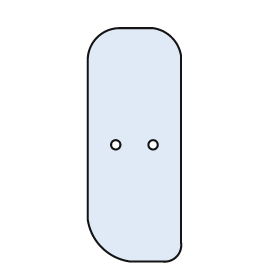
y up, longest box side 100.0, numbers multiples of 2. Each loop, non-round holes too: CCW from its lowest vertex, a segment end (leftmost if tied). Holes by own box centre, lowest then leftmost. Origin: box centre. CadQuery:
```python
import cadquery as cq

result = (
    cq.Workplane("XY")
    .moveTo(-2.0, -50.0)
    .lineTo(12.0, -50.0)
    .threePointArc((18.0, -48.0), (20.0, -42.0))
    .lineTo(20.0, 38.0)
    .threePointArc((16.0, 46.0), (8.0, 50.0))
    .lineTo(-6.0, 50.0)
    .threePointArc((-16.0, 46.0), (-20.0, 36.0))
    .lineTo(-20.0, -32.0)
    .threePointArc((-14.0, -44.0), (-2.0, -50.0))
    .close()
    .moveTo(-8.0, 0.0)
    .circle(2.0)
    .moveTo(8.0, 0.0)
    .circle(2.0)
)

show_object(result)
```